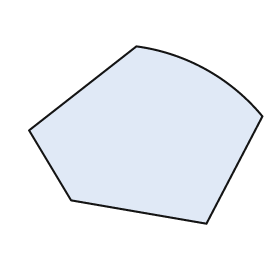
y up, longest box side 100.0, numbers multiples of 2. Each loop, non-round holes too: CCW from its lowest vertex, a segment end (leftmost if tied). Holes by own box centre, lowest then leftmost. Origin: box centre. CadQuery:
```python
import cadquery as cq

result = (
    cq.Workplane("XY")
    .moveTo(26.0, -38.0)
    .lineTo(50.0, 8.0)
    .threePointArc((26.0, 28.0), (-4.0, 38.0))
    .lineTo(-50.0, 2.0)
    .lineTo(-32.0, -28.0)
    .close()
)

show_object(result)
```